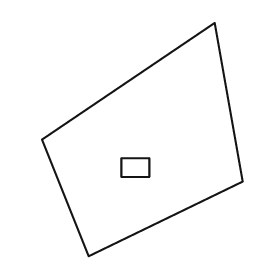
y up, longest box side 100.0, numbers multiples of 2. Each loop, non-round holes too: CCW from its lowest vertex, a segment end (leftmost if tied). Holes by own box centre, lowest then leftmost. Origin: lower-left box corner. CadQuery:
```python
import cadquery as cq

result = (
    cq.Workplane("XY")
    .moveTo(20.0, 0.0)
    .lineTo(86.0, 32.0)
    .lineTo(74.0, 100.0)
    .lineTo(0.0, 50.0)
    .close()
    .moveTo(34.0, 34.0)
    .lineTo(46.0, 34.0)
    .lineTo(46.0, 42.0)
    .lineTo(34.0, 42.0)
    .close()
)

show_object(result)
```